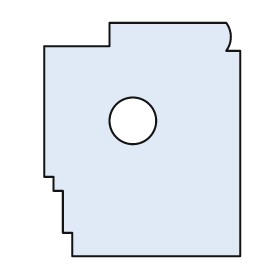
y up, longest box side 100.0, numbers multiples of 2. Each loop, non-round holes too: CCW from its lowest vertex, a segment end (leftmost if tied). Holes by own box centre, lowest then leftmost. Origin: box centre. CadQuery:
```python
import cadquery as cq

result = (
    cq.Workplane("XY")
    .moveTo(-30.0, -50.0)
    .lineTo(42.0, -50.0)
    .lineTo(42.0, 38.0)
    .lineTo(36.0, 38.0)
    .threePointArc((38.0, 44.0), (36.0, 50.0))
    .lineTo(-14.0, 50.0)
    .lineTo(-14.0, 40.0)
    .lineTo(-42.0, 40.0)
    .lineTo(-42.0, -16.0)
    .lineTo(-38.0, -16.0)
    .lineTo(-38.0, -22.0)
    .lineTo(-34.0, -22.0)
    .lineTo(-34.0, -40.0)
    .lineTo(-30.0, -40.0)
    .close()
    .moveTo(-4.0, 8.0)
    .circle(10.0)
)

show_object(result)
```